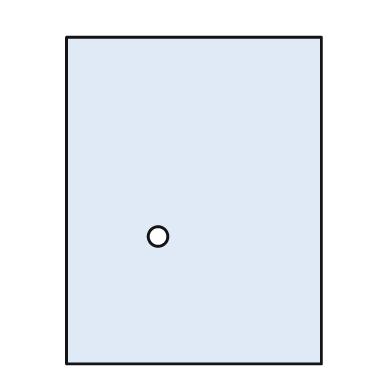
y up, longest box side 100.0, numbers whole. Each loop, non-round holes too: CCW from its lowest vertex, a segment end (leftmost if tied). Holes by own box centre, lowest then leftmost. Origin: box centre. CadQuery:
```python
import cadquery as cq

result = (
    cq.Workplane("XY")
    .moveTo(-39.0, -50.0)
    .lineTo(39.0, -50.0)
    .lineTo(39.0, 50.0)
    .lineTo(-39.0, 50.0)
    .close()
    .moveTo(-11.0, -11.0)
    .circle(3.0)
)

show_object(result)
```